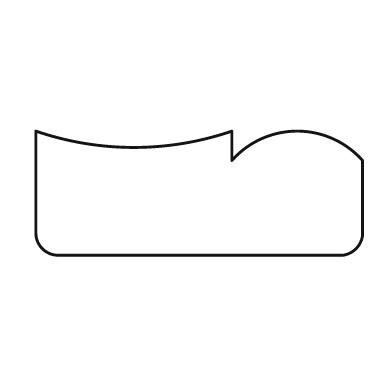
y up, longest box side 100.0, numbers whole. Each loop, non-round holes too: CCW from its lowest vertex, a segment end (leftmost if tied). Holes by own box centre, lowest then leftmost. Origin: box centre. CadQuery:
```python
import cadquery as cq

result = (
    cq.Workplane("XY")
    .moveTo(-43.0, -19.0)
    .lineTo(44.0, -19.0)
    .threePointArc((48.0, -17.0), (50.0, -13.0))
    .lineTo(50.0, 10.0)
    .threePointArc((30.0, 19.0), (10.0, 10.0))
    .lineTo(10.0, 19.0)
    .threePointArc((-20.0, 14.0), (-50.0, 19.0))
    .lineTo(-50.0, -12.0)
    .threePointArc((-48.0, -17.0), (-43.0, -19.0))
    .close()
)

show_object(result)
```